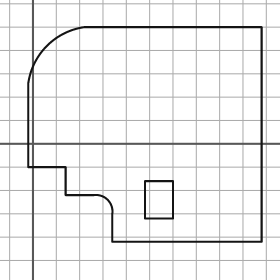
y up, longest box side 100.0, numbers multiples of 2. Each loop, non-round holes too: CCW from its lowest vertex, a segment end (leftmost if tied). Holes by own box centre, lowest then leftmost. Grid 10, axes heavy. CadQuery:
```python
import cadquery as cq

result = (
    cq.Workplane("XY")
    .moveTo(34.0, -42.0)
    .lineTo(98.0, -42.0)
    .lineTo(98.0, 50.0)
    .lineTo(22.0, 50.0)
    .threePointArc((6.0, 42.0), (-2.0, 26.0))
    .lineTo(-2.0, -10.0)
    .lineTo(14.0, -10.0)
    .lineTo(14.0, -22.0)
    .lineTo(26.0, -22.0)
    .threePointArc((32.0, -24.0), (34.0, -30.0))
    .close()
    .moveTo(48.0, -32.0)
    .lineTo(60.0, -32.0)
    .lineTo(60.0, -16.0)
    .lineTo(48.0, -16.0)
    .close()
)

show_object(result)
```